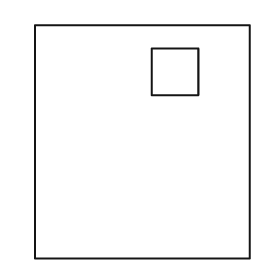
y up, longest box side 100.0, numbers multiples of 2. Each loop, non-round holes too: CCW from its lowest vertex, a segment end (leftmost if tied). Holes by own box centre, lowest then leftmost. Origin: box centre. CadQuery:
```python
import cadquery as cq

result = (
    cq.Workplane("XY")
    .moveTo(-46.0, -50.0)
    .lineTo(46.0, -50.0)
    .lineTo(46.0, 50.0)
    .lineTo(-46.0, 50.0)
    .close()
    .moveTo(4.0, 20.0)
    .lineTo(24.0, 20.0)
    .lineTo(24.0, 40.0)
    .lineTo(4.0, 40.0)
    .close()
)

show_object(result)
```